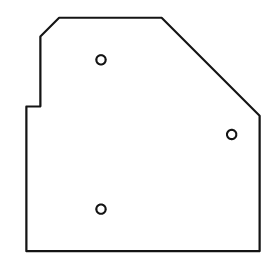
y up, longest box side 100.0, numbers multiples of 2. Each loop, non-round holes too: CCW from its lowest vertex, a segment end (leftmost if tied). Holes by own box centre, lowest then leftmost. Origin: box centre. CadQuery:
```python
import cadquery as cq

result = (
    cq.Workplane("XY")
    .moveTo(-50.0, -50.0)
    .lineTo(50.0, -50.0)
    .lineTo(50.0, 8.0)
    .lineTo(8.0, 50.0)
    .lineTo(-36.0, 50.0)
    .lineTo(-44.0, 42.0)
    .lineTo(-44.0, 12.0)
    .lineTo(-50.0, 12.0)
    .close()
    .moveTo(-18.0, -32.0)
    .circle(2.0)
    .moveTo(38.0, 0.0)
    .circle(2.0)
    .moveTo(-18.0, 32.0)
    .circle(2.0)
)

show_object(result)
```